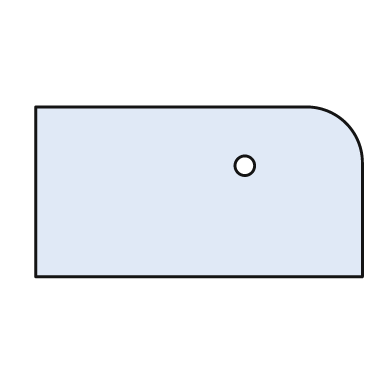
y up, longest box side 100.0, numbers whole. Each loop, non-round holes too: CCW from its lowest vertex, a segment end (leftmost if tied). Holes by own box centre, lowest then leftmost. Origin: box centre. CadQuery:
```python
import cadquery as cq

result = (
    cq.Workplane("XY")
    .moveTo(-50.0, -26.0)
    .lineTo(50.0, -26.0)
    .lineTo(50.0, 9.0)
    .threePointArc((45.0, 21.0), (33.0, 26.0))
    .lineTo(-50.0, 26.0)
    .close()
    .moveTo(14.0, 8.0)
    .circle(3.0)
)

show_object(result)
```